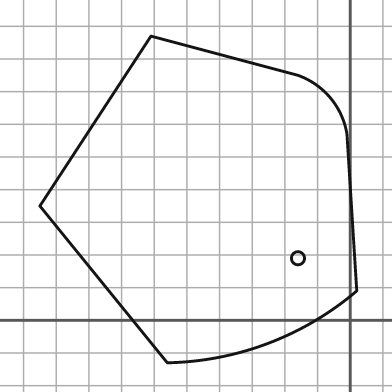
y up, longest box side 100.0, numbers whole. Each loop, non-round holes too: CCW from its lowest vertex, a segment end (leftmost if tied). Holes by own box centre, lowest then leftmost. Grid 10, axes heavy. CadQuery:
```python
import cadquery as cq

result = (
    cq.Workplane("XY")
    .moveTo(-56.0, -13.0)
    .threePointArc((-25.0, -7.0), (2.0, 9.0))
    .lineTo(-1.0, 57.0)
    .threePointArc((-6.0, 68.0), (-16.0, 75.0))
    .lineTo(-61.0, 87.0)
    .lineTo(-95.0, 35.0)
    .close()
    .moveTo(-16.0, 19.0)
    .circle(2.0)
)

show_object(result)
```